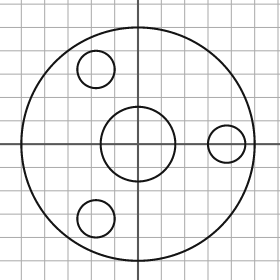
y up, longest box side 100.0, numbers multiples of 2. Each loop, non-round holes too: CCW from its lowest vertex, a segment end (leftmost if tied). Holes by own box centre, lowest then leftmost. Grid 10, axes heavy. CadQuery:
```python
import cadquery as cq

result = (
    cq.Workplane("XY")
    .moveTo(0.0, 0.0)
    .circle(50.0)
    .moveTo(-18.0, -32.0)
    .circle(8.0)
    .moveTo(0.0, 0.0)
    .circle(16.0)
    .moveTo(38.0, 0.0)
    .circle(8.0)
    .moveTo(-18.0, 32.0)
    .circle(8.0)
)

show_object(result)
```